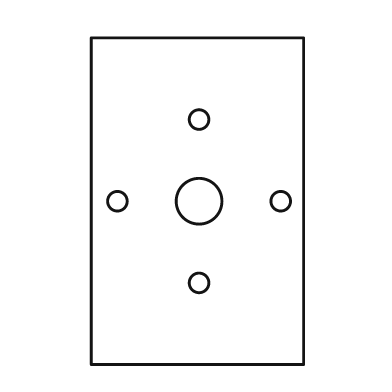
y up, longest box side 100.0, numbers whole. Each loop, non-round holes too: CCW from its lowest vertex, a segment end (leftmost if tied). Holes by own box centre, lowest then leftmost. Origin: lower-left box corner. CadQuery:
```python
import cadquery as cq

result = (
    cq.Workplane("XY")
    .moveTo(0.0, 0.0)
    .lineTo(65.0, 0.0)
    .lineTo(65.0, 100.0)
    .lineTo(0.0, 100.0)
    .close()
    .moveTo(33.0, 25.0)
    .circle(3.0)
    .moveTo(8.0, 50.0)
    .circle(3.0)
    .moveTo(33.0, 50.0)
    .circle(7.0)
    .moveTo(58.0, 50.0)
    .circle(3.0)
    .moveTo(33.0, 75.0)
    .circle(3.0)
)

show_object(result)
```